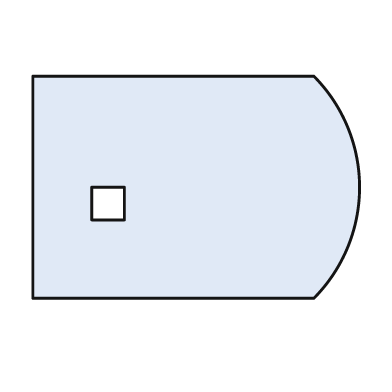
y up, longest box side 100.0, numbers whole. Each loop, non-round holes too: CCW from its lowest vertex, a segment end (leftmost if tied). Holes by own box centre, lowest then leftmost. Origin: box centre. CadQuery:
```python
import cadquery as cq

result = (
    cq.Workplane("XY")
    .moveTo(-50.0, -34.0)
    .lineTo(36.0, -34.0)
    .threePointArc((50.0, 0.0), (36.0, 34.0))
    .lineTo(-50.0, 34.0)
    .close()
    .moveTo(-32.0, -10.0)
    .lineTo(-22.0, -10.0)
    .lineTo(-22.0, 0.0)
    .lineTo(-32.0, 0.0)
    .close()
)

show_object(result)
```